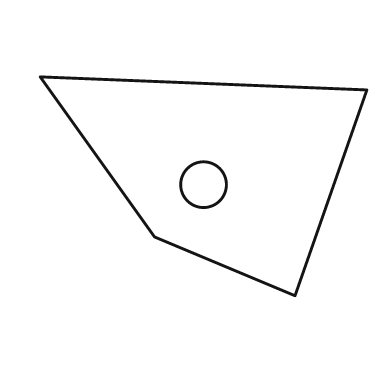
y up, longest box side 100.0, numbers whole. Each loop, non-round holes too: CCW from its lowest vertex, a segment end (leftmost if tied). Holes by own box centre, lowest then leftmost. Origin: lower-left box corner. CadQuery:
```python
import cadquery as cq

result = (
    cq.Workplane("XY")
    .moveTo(78.0, 0.0)
    .lineTo(100.0, 63.0)
    .lineTo(0.0, 67.0)
    .lineTo(35.0, 18.0)
    .close()
    .moveTo(50.0, 34.0)
    .circle(7.0)
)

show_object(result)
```